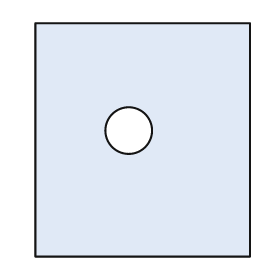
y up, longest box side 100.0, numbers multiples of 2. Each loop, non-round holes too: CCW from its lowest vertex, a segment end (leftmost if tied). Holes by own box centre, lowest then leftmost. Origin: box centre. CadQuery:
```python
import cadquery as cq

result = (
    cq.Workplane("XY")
    .moveTo(-46.0, -50.0)
    .lineTo(46.0, -50.0)
    .lineTo(46.0, 50.0)
    .lineTo(-46.0, 50.0)
    .close()
    .moveTo(-6.0, 4.0)
    .circle(10.0)
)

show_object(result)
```